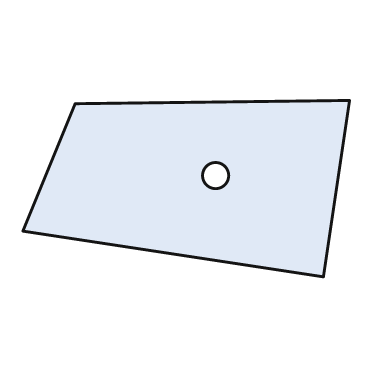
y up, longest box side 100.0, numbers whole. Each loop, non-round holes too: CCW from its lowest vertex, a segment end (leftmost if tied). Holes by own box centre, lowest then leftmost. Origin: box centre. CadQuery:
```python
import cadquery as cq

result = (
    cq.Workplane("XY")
    .moveTo(42.0, -27.0)
    .lineTo(50.0, 27.0)
    .lineTo(-34.0, 26.0)
    .lineTo(-50.0, -13.0)
    .close()
    .moveTo(9.0, 4.0)
    .circle(4.0)
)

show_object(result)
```